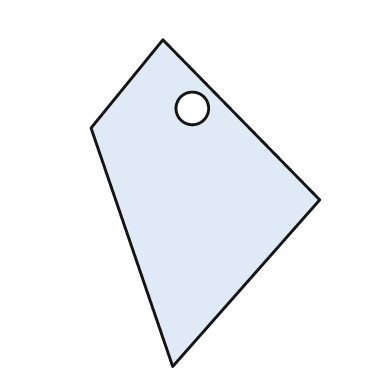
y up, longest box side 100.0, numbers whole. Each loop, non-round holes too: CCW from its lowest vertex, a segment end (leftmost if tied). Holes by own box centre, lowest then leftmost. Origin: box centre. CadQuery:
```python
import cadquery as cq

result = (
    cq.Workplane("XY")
    .moveTo(-10.0, -50.0)
    .lineTo(35.0, 1.0)
    .lineTo(-13.0, 50.0)
    .lineTo(-35.0, 23.0)
    .close()
    .moveTo(-4.0, 29.0)
    .circle(5.0)
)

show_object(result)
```